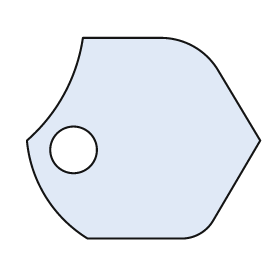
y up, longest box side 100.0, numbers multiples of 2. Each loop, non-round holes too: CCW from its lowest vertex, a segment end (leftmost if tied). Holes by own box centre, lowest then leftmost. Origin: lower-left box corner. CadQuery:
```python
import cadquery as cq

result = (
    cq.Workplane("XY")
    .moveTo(26.0, 0.0)
    .lineTo(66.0, 0.0)
    .threePointArc((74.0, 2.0), (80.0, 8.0))
    .lineTo(100.0, 42.0)
    .lineTo(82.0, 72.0)
    .threePointArc((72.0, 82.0), (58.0, 86.0))
    .lineTo(24.0, 86.0)
    .threePointArc((16.0, 62.0), (0.0, 42.0))
    .threePointArc((8.0, 18.0), (26.0, 0.0))
    .close()
    .moveTo(20.0, 38.0)
    .circle(10.0)
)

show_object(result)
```